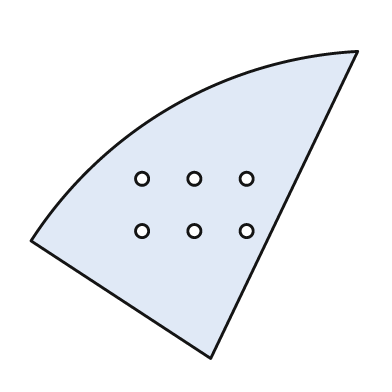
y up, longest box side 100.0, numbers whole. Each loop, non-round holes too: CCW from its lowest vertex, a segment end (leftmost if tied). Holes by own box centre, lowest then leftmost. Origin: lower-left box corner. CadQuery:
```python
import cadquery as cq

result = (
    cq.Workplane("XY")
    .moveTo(55.0, 0.0)
    .lineTo(100.0, 94.0)
    .threePointArc((43.0, 77.0), (0.0, 36.0))
    .close()
    .moveTo(34.0, 39.0)
    .circle(2.0)
    .moveTo(50.0, 39.0)
    .circle(2.0)
    .moveTo(66.0, 39.0)
    .circle(2.0)
    .moveTo(34.0, 55.0)
    .circle(2.0)
    .moveTo(50.0, 55.0)
    .circle(2.0)
    .moveTo(66.0, 55.0)
    .circle(2.0)
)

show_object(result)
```